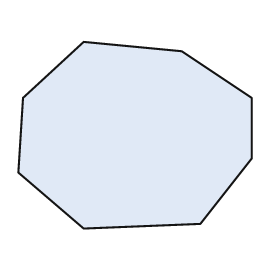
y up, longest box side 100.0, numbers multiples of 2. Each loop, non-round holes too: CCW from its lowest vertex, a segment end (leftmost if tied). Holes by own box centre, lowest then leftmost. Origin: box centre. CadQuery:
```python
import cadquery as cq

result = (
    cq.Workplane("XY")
    .moveTo(-22.0, -40.0)
    .lineTo(28.0, -38.0)
    .lineTo(50.0, -10.0)
    .lineTo(50.0, 16.0)
    .lineTo(20.0, 36.0)
    .lineTo(-22.0, 40.0)
    .lineTo(-48.0, 16.0)
    .lineTo(-50.0, -16.0)
    .close()
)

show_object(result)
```